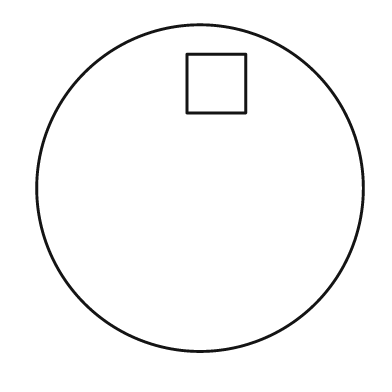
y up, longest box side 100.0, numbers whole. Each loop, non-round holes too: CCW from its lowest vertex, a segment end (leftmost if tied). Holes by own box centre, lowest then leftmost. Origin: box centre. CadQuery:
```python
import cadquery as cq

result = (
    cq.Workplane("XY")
    .moveTo(0.0, 0.0)
    .circle(50.0)
    .moveTo(-4.0, 23.0)
    .lineTo(14.0, 23.0)
    .lineTo(14.0, 41.0)
    .lineTo(-4.0, 41.0)
    .close()
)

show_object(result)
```